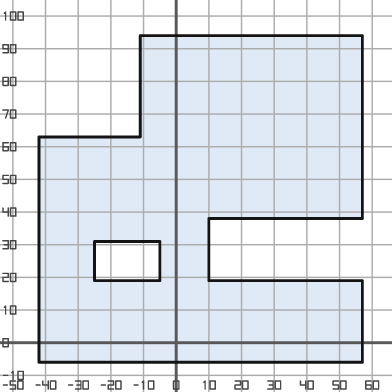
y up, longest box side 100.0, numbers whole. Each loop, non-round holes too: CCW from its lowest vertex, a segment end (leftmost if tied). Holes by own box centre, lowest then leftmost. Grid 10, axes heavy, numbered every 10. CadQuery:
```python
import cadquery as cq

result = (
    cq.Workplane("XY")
    .moveTo(-42.0, -6.0)
    .lineTo(57.0, -6.0)
    .lineTo(57.0, 19.0)
    .lineTo(10.0, 19.0)
    .lineTo(10.0, 38.0)
    .lineTo(57.0, 38.0)
    .lineTo(57.0, 94.0)
    .lineTo(-11.0, 94.0)
    .lineTo(-11.0, 63.0)
    .lineTo(-42.0, 63.0)
    .close()
    .moveTo(-25.0, 19.0)
    .lineTo(-5.0, 19.0)
    .lineTo(-5.0, 31.0)
    .lineTo(-25.0, 31.0)
    .close()
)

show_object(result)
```